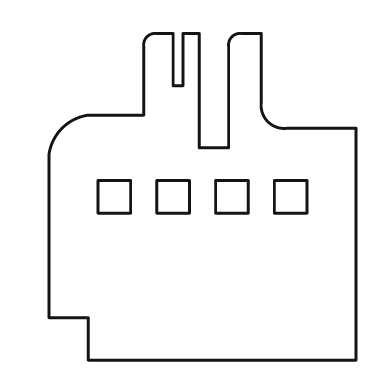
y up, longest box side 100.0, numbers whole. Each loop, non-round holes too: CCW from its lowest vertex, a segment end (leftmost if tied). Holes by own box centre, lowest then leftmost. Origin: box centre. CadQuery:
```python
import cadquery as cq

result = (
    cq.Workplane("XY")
    .moveTo(-35.0, -50.0)
    .lineTo(47.0, -50.0)
    .lineTo(47.0, 21.0)
    .lineTo(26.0, 21.0)
    .threePointArc((20.0, 23.0), (18.0, 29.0))
    .lineTo(18.0, 50.0)
    .lineTo(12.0, 50.0)
    .threePointArc((9.0, 49.0), (8.0, 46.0))
    .lineTo(8.0, 15.0)
    .lineTo(-1.0, 15.0)
    .lineTo(-1.0, 50.0)
    .lineTo(-6.0, 50.0)
    .lineTo(-6.0, 34.0)
    .lineTo(-9.0, 34.0)
    .lineTo(-9.0, 50.0)
    .lineTo(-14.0, 50.0)
    .threePointArc((-17.0, 49.0), (-18.0, 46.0))
    .lineTo(-18.0, 25.0)
    .lineTo(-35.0, 25.0)
    .threePointArc((-43.0, 21.0), (-47.0, 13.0))
    .lineTo(-47.0, -37.0)
    .lineTo(-35.0, -37.0)
    .close()
    .moveTo(-32.0, -5.0)
    .lineTo(-22.0, -5.0)
    .lineTo(-22.0, 5.0)
    .lineTo(-32.0, 5.0)
    .close()
    .moveTo(-14.0, -5.0)
    .lineTo(-4.0, -5.0)
    .lineTo(-4.0, 5.0)
    .lineTo(-14.0, 5.0)
    .close()
    .moveTo(4.0, -5.0)
    .lineTo(14.0, -5.0)
    .lineTo(14.0, 5.0)
    .lineTo(4.0, 5.0)
    .close()
    .moveTo(22.0, -5.0)
    .lineTo(32.0, -5.0)
    .lineTo(32.0, 5.0)
    .lineTo(22.0, 5.0)
    .close()
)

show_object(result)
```